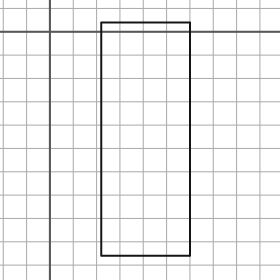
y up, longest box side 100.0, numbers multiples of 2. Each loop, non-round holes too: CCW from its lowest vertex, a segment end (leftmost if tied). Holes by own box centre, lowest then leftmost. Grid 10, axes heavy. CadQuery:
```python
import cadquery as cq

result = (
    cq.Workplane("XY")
    .moveTo(22.0, -96.0)
    .lineTo(60.0, -96.0)
    .lineTo(60.0, 4.0)
    .lineTo(22.0, 4.0)
    .close()
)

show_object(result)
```